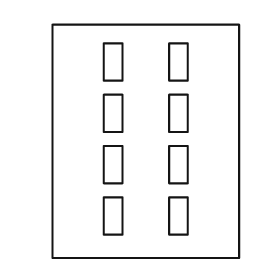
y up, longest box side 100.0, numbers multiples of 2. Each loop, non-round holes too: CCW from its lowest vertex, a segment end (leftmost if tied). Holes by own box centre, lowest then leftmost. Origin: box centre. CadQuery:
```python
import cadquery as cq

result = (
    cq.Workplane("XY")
    .moveTo(-40.0, -50.0)
    .lineTo(40.0, -50.0)
    .lineTo(40.0, 50.0)
    .lineTo(-40.0, 50.0)
    .close()
    .moveTo(-18.0, -40.0)
    .lineTo(-10.0, -40.0)
    .lineTo(-10.0, -24.0)
    .lineTo(-18.0, -24.0)
    .close()
    .moveTo(10.0, -40.0)
    .lineTo(18.0, -40.0)
    .lineTo(18.0, -24.0)
    .lineTo(10.0, -24.0)
    .close()
    .moveTo(-18.0, -18.0)
    .lineTo(-10.0, -18.0)
    .lineTo(-10.0, -2.0)
    .lineTo(-18.0, -2.0)
    .close()
    .moveTo(10.0, -18.0)
    .lineTo(18.0, -18.0)
    .lineTo(18.0, -2.0)
    .lineTo(10.0, -2.0)
    .close()
    .moveTo(-18.0, 4.0)
    .lineTo(-10.0, 4.0)
    .lineTo(-10.0, 20.0)
    .lineTo(-18.0, 20.0)
    .close()
    .moveTo(10.0, 4.0)
    .lineTo(18.0, 4.0)
    .lineTo(18.0, 20.0)
    .lineTo(10.0, 20.0)
    .close()
    .moveTo(-18.0, 26.0)
    .lineTo(-10.0, 26.0)
    .lineTo(-10.0, 42.0)
    .lineTo(-18.0, 42.0)
    .close()
    .moveTo(10.0, 26.0)
    .lineTo(18.0, 26.0)
    .lineTo(18.0, 42.0)
    .lineTo(10.0, 42.0)
    .close()
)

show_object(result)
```